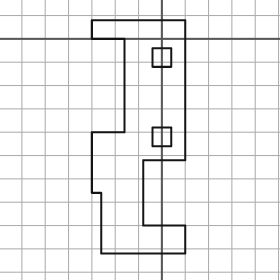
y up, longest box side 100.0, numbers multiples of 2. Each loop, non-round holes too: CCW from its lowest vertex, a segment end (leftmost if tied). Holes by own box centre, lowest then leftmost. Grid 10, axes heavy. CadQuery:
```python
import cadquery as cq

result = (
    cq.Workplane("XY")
    .moveTo(-26.0, -92.0)
    .lineTo(10.0, -92.0)
    .lineTo(10.0, -80.0)
    .lineTo(-8.0, -80.0)
    .lineTo(-8.0, -52.0)
    .lineTo(10.0, -52.0)
    .lineTo(10.0, 8.0)
    .lineTo(-30.0, 8.0)
    .lineTo(-30.0, 0.0)
    .lineTo(-16.0, 0.0)
    .lineTo(-16.0, -40.0)
    .lineTo(-30.0, -40.0)
    .lineTo(-30.0, -66.0)
    .lineTo(-26.0, -66.0)
    .close()
    .moveTo(-4.0, -46.0)
    .lineTo(4.0, -46.0)
    .lineTo(4.0, -38.0)
    .lineTo(-4.0, -38.0)
    .close()
    .moveTo(-4.0, -12.0)
    .lineTo(4.0, -12.0)
    .lineTo(4.0, -4.0)
    .lineTo(-4.0, -4.0)
    .close()
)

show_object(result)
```